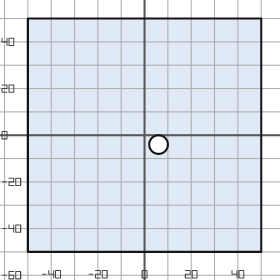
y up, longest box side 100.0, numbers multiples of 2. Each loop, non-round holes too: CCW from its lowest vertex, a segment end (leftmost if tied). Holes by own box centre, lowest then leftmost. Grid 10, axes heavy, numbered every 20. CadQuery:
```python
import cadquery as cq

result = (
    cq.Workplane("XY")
    .moveTo(-50.0, -50.0)
    .lineTo(50.0, -50.0)
    .lineTo(50.0, 50.0)
    .lineTo(-50.0, 50.0)
    .close()
    .moveTo(6.0, -4.0)
    .circle(4.0)
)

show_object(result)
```